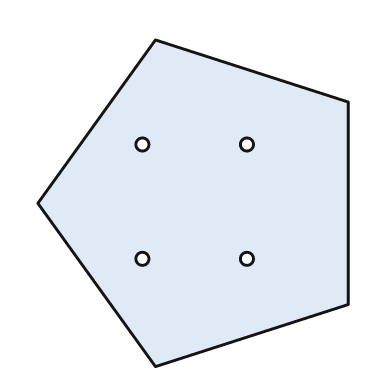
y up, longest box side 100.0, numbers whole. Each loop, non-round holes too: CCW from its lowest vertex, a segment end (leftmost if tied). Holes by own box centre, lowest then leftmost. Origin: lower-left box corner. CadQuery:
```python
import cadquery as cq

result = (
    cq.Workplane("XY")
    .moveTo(36.0, 0.0)
    .lineTo(95.0, 19.0)
    .lineTo(95.0, 81.0)
    .lineTo(36.0, 100.0)
    .lineTo(0.0, 50.0)
    .close()
    .moveTo(32.0, 33.0)
    .circle(2.0)
    .moveTo(64.0, 33.0)
    .circle(2.0)
    .moveTo(32.0, 68.0)
    .circle(2.0)
    .moveTo(64.0, 68.0)
    .circle(2.0)
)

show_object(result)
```